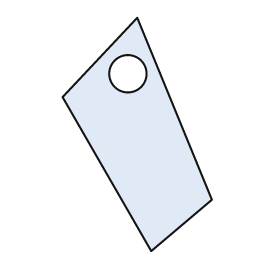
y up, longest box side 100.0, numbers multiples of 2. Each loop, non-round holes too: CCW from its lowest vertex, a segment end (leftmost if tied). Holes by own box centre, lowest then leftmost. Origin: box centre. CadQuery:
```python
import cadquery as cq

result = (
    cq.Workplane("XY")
    .moveTo(6.0, -50.0)
    .lineTo(32.0, -28.0)
    .lineTo(0.0, 50.0)
    .lineTo(-32.0, 16.0)
    .close()
    .moveTo(-4.0, 26.0)
    .circle(8.0)
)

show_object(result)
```